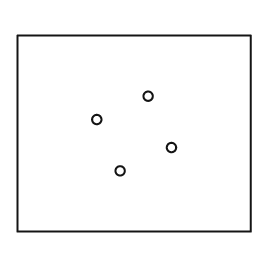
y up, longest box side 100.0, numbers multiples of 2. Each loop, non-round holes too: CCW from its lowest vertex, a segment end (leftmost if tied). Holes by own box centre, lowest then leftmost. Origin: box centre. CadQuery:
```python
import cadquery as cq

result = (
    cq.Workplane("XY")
    .moveTo(-50.0, -42.0)
    .lineTo(50.0, -42.0)
    .lineTo(50.0, 42.0)
    .lineTo(-50.0, 42.0)
    .close()
    .moveTo(-6.0, -16.0)
    .circle(2.0)
    .moveTo(16.0, -6.0)
    .circle(2.0)
    .moveTo(-16.0, 6.0)
    .circle(2.0)
    .moveTo(6.0, 16.0)
    .circle(2.0)
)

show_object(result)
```